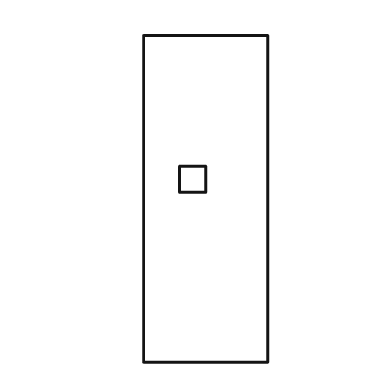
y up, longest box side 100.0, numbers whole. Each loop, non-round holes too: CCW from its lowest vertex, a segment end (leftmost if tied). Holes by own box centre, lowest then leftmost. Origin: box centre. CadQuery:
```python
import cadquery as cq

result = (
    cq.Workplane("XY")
    .moveTo(-19.0, -50.0)
    .lineTo(19.0, -50.0)
    .lineTo(19.0, 50.0)
    .lineTo(-19.0, 50.0)
    .close()
    .moveTo(-8.0, 2.0)
    .lineTo(0.0, 2.0)
    .lineTo(0.0, 10.0)
    .lineTo(-8.0, 10.0)
    .close()
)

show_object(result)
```